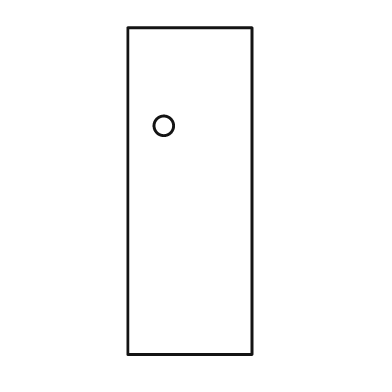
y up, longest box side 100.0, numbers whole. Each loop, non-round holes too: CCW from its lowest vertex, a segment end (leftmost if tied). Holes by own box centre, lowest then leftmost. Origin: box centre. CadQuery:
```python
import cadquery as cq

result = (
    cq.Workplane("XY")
    .moveTo(-19.0, -50.0)
    .lineTo(19.0, -50.0)
    .lineTo(19.0, 50.0)
    .lineTo(-19.0, 50.0)
    .close()
    .moveTo(-8.0, 20.0)
    .circle(3.0)
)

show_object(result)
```